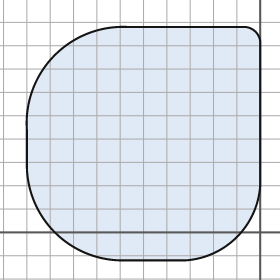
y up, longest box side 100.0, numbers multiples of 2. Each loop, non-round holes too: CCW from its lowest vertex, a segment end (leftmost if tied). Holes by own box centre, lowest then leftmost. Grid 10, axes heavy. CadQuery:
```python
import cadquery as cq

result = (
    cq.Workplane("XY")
    .moveTo(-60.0, -12.0)
    .lineTo(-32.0, -12.0)
    .threePointArc((-10.0, -2.0), (0.0, 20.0))
    .lineTo(0.0, 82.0)
    .threePointArc((-2.0, 86.0), (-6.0, 88.0))
    .lineTo(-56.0, 88.0)
    .threePointArc((-88.0, 76.0), (-100.0, 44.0))
    .lineTo(-100.0, 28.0)
    .threePointArc((-88.0, 0.0), (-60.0, -12.0))
    .close()
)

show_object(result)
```